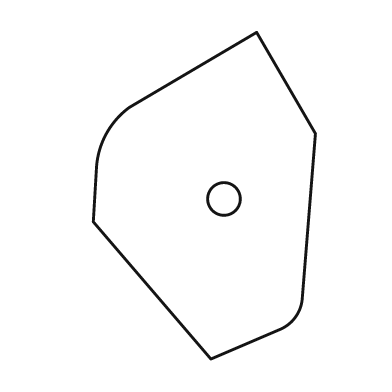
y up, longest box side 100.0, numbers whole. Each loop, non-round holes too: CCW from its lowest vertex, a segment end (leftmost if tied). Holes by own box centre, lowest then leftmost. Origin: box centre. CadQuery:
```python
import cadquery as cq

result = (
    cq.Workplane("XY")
    .moveTo(2.0, -50.0)
    .lineTo(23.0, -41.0)
    .threePointArc((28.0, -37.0), (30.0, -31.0))
    .lineTo(34.0, 19.0)
    .lineTo(16.0, 50.0)
    .lineTo(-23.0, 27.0)
    .threePointArc((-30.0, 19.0), (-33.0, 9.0))
    .lineTo(-34.0, -8.0)
    .close()
    .moveTo(6.0, -1.0)
    .circle(5.0)
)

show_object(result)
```